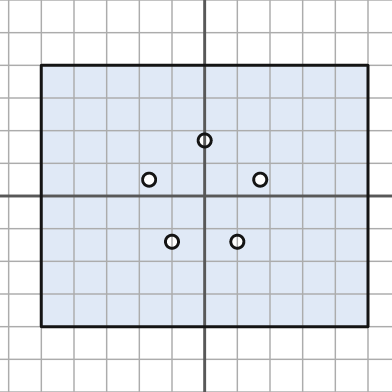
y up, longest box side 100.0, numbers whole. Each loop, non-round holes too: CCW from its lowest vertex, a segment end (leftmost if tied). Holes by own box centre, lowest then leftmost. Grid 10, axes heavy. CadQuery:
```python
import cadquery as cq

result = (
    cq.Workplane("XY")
    .moveTo(-50.0, -40.0)
    .lineTo(50.0, -40.0)
    .lineTo(50.0, 40.0)
    .lineTo(-50.0, 40.0)
    .close()
    .moveTo(-10.0, -14.0)
    .circle(2.0)
    .moveTo(10.0, -14.0)
    .circle(2.0)
    .moveTo(-17.0, 5.0)
    .circle(2.0)
    .moveTo(17.0, 5.0)
    .circle(2.0)
    .moveTo(0.0, 17.0)
    .circle(2.0)
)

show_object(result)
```